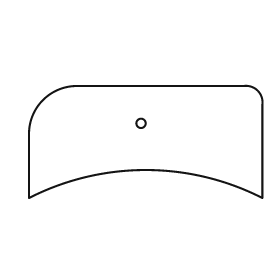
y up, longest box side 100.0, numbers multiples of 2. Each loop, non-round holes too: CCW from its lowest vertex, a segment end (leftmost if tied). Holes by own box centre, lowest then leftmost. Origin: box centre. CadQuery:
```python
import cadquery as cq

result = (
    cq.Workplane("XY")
    .moveTo(-50.0, -24.0)
    .threePointArc((0.0, -12.0), (50.0, -24.0))
    .lineTo(50.0, 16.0)
    .threePointArc((48.0, 22.0), (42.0, 24.0))
    .lineTo(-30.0, 24.0)
    .threePointArc((-44.0, 18.0), (-50.0, 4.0))
    .close()
    .moveTo(-2.0, 8.0)
    .circle(2.0)
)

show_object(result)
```